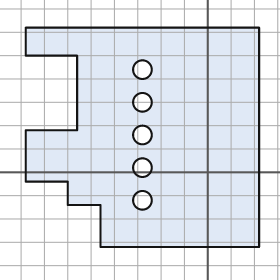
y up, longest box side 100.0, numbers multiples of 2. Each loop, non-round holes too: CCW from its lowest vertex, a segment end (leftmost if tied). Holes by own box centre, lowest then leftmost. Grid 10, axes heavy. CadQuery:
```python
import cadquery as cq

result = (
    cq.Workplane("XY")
    .moveTo(-46.0, -32.0)
    .lineTo(22.0, -32.0)
    .lineTo(22.0, 62.0)
    .lineTo(-78.0, 62.0)
    .lineTo(-78.0, 50.0)
    .lineTo(-56.0, 50.0)
    .lineTo(-56.0, 18.0)
    .lineTo(-78.0, 18.0)
    .lineTo(-78.0, -4.0)
    .lineTo(-60.0, -4.0)
    .lineTo(-60.0, -14.0)
    .lineTo(-46.0, -14.0)
    .close()
    .moveTo(-28.0, -12.0)
    .circle(4.0)
    .moveTo(-28.0, 2.0)
    .circle(4.0)
    .moveTo(-28.0, 16.0)
    .circle(4.0)
    .moveTo(-28.0, 30.0)
    .circle(4.0)
    .moveTo(-28.0, 44.0)
    .circle(4.0)
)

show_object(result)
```